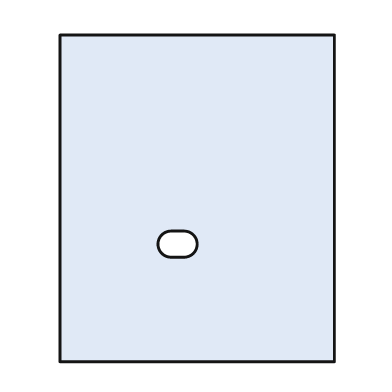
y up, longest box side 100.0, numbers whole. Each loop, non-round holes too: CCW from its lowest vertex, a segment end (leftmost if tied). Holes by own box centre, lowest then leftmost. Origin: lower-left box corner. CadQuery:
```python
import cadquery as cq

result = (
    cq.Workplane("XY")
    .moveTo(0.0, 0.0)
    .lineTo(84.0, 0.0)
    .lineTo(84.0, 100.0)
    .lineTo(0.0, 100.0)
    .close()
    .moveTo(34.0, 32.0)
    .lineTo(38.0, 32.0)
    .threePointArc((42.0, 36.0), (38.0, 40.0))
    .lineTo(34.0, 40.0)
    .threePointArc((30.0, 36.0), (34.0, 32.0))
    .close()
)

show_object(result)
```